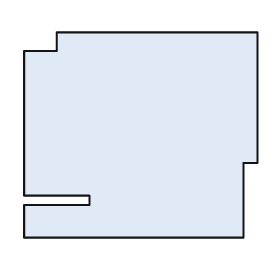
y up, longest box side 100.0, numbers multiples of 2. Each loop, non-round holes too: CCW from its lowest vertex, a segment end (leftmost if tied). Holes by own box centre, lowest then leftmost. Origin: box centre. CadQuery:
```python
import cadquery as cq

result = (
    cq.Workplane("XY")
    .moveTo(-50.0, -44.0)
    .lineTo(44.0, -44.0)
    .lineTo(44.0, -12.0)
    .lineTo(50.0, -12.0)
    .lineTo(50.0, 44.0)
    .lineTo(-36.0, 44.0)
    .lineTo(-36.0, 36.0)
    .lineTo(-50.0, 36.0)
    .lineTo(-50.0, -26.0)
    .lineTo(-22.0, -26.0)
    .lineTo(-22.0, -30.0)
    .lineTo(-50.0, -30.0)
    .close()
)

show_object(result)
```